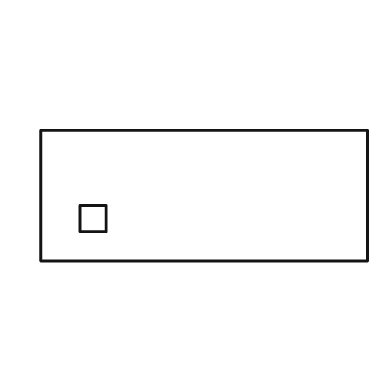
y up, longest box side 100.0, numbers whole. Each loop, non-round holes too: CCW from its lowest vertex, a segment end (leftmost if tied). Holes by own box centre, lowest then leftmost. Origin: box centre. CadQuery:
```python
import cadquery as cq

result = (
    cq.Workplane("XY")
    .moveTo(-50.0, -20.0)
    .lineTo(50.0, -20.0)
    .lineTo(50.0, 20.0)
    .lineTo(-50.0, 20.0)
    .close()
    .moveTo(-38.0, -11.0)
    .lineTo(-30.0, -11.0)
    .lineTo(-30.0, -3.0)
    .lineTo(-38.0, -3.0)
    .close()
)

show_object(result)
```